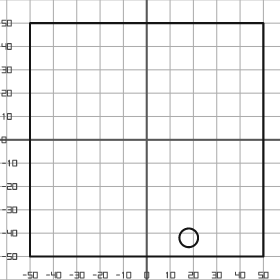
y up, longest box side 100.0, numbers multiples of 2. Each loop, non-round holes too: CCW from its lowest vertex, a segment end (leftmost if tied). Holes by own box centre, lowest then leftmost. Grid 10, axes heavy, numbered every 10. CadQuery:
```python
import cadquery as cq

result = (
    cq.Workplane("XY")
    .moveTo(-50.0, -50.0)
    .lineTo(50.0, -50.0)
    .lineTo(50.0, 50.0)
    .lineTo(-50.0, 50.0)
    .close()
    .moveTo(18.0, -42.0)
    .circle(4.0)
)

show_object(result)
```